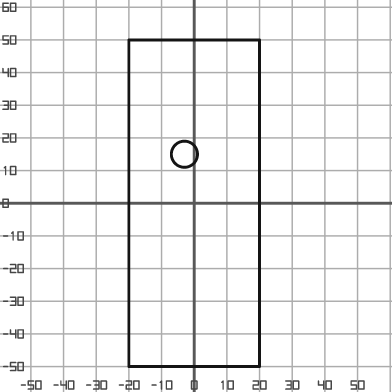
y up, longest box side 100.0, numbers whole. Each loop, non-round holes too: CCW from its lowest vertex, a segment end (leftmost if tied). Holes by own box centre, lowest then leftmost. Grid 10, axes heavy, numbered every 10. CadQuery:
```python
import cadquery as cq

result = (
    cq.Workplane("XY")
    .moveTo(-20.0, -50.0)
    .lineTo(20.0, -50.0)
    .lineTo(20.0, 50.0)
    .lineTo(-20.0, 50.0)
    .close()
    .moveTo(-3.0, 15.0)
    .circle(4.0)
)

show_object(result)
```